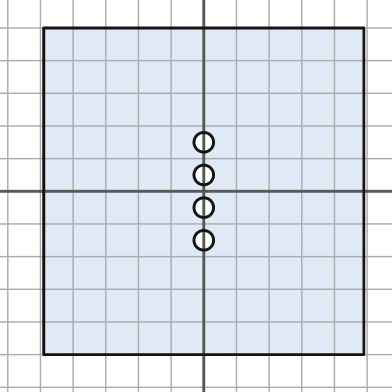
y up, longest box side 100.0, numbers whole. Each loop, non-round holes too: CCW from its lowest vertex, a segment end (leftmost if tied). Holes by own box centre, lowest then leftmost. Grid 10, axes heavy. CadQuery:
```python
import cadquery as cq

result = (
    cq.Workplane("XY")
    .moveTo(-49.0, -50.0)
    .lineTo(49.0, -50.0)
    .lineTo(49.0, 50.0)
    .lineTo(-49.0, 50.0)
    .close()
    .moveTo(0.0, -15.0)
    .circle(3.0)
    .moveTo(0.0, -5.0)
    .circle(3.0)
    .moveTo(0.0, 5.0)
    .circle(3.0)
    .moveTo(0.0, 15.0)
    .circle(3.0)
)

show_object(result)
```